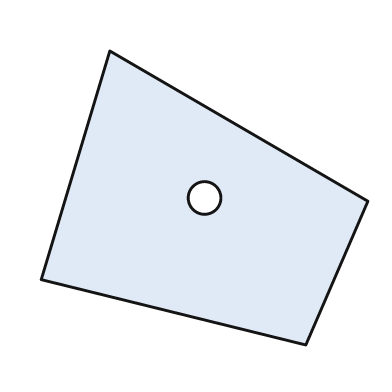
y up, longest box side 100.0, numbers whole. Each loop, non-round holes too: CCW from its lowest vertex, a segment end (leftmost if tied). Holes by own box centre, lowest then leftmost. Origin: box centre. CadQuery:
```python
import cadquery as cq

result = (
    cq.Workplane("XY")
    .moveTo(31.0, -45.0)
    .lineTo(50.0, -1.0)
    .lineTo(-29.0, 45.0)
    .lineTo(-50.0, -25.0)
    .close()
    .moveTo(0.0, 0.0)
    .circle(5.0)
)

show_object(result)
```